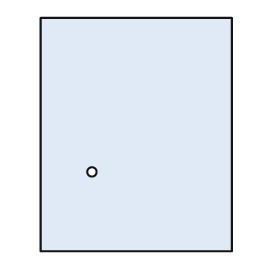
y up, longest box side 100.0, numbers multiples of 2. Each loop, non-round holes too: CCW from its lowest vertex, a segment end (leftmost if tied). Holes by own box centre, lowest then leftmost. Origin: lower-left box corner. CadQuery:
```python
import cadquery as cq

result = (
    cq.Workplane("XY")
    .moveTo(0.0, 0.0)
    .lineTo(82.0, 0.0)
    .lineTo(82.0, 100.0)
    .lineTo(0.0, 100.0)
    .close()
    .moveTo(22.0, 34.0)
    .circle(2.0)
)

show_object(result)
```